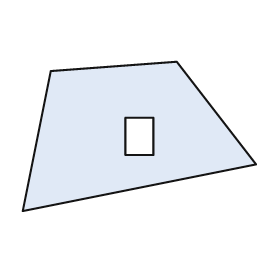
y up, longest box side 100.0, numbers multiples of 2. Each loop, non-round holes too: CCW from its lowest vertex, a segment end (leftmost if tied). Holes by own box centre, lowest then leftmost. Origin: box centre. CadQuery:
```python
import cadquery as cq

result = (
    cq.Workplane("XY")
    .moveTo(-50.0, -32.0)
    .lineTo(50.0, -12.0)
    .lineTo(16.0, 32.0)
    .lineTo(-38.0, 28.0)
    .close()
    .moveTo(-6.0, -8.0)
    .lineTo(6.0, -8.0)
    .lineTo(6.0, 8.0)
    .lineTo(-6.0, 8.0)
    .close()
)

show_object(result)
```